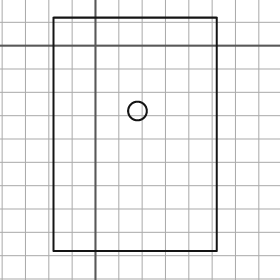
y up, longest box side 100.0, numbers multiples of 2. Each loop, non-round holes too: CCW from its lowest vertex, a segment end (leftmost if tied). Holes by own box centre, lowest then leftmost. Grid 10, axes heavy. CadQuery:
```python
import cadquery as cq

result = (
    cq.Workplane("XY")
    .moveTo(-18.0, -88.0)
    .lineTo(52.0, -88.0)
    .lineTo(52.0, 12.0)
    .lineTo(-18.0, 12.0)
    .close()
    .moveTo(18.0, -28.0)
    .circle(4.0)
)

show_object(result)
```